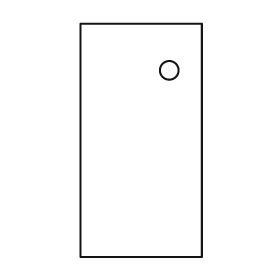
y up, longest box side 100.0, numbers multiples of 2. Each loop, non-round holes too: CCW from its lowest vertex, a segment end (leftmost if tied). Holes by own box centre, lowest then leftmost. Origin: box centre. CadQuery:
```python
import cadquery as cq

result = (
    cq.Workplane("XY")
    .moveTo(-26.0, -50.0)
    .lineTo(26.0, -50.0)
    .lineTo(26.0, 50.0)
    .lineTo(-26.0, 50.0)
    .close()
    .moveTo(12.0, 30.0)
    .circle(4.0)
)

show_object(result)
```